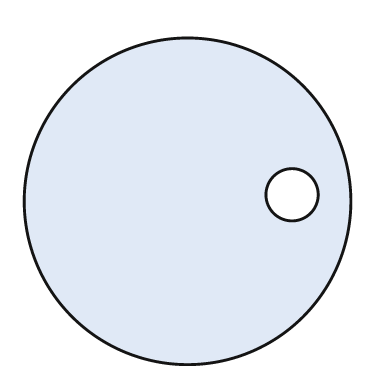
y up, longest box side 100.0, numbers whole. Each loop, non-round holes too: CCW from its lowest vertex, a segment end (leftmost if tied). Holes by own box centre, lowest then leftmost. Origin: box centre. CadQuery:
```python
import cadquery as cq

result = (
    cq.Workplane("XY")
    .moveTo(0.0, 0.0)
    .circle(50.0)
    .moveTo(32.0, 2.0)
    .circle(8.0)
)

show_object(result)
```